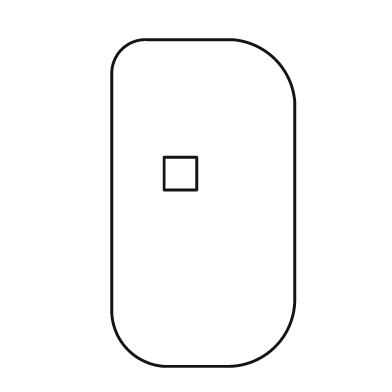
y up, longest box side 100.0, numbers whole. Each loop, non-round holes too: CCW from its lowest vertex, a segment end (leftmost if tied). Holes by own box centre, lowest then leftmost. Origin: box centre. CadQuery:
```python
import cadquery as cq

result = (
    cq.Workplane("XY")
    .moveTo(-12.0, -50.0)
    .lineTo(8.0, -50.0)
    .threePointArc((22.0, -44.0), (28.0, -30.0))
    .lineTo(28.0, 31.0)
    .threePointArc((22.0, 44.0), (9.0, 50.0))
    .lineTo(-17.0, 50.0)
    .threePointArc((-25.0, 47.0), (-28.0, 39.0))
    .lineTo(-28.0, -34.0)
    .threePointArc((-23.0, -45.0), (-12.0, -50.0))
    .close()
    .moveTo(-12.0, 4.0)
    .lineTo(-2.0, 4.0)
    .lineTo(-2.0, 14.0)
    .lineTo(-12.0, 14.0)
    .close()
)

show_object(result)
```